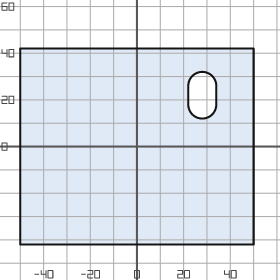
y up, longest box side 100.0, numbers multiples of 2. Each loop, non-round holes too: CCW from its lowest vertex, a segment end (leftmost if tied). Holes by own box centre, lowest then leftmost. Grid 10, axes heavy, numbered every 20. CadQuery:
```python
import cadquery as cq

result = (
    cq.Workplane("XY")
    .moveTo(-50.0, -42.0)
    .lineTo(50.0, -42.0)
    .lineTo(50.0, 42.0)
    .lineTo(-50.0, 42.0)
    .close()
    .moveTo(22.0, 18.0)
    .threePointArc((28.0, 12.0), (34.0, 18.0))
    .lineTo(34.0, 26.0)
    .threePointArc((28.0, 32.0), (22.0, 26.0))
    .close()
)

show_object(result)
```